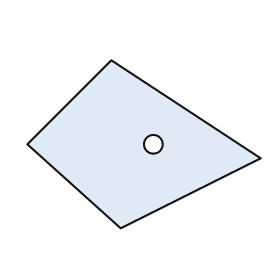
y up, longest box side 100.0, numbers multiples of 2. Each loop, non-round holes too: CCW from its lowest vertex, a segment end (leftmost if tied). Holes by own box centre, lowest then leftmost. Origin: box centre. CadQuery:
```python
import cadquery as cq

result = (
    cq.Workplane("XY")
    .moveTo(-10.0, -36.0)
    .lineTo(50.0, -6.0)
    .lineTo(-14.0, 36.0)
    .lineTo(-50.0, 0.0)
    .close()
    .moveTo(4.0, 0.0)
    .circle(4.0)
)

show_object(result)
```